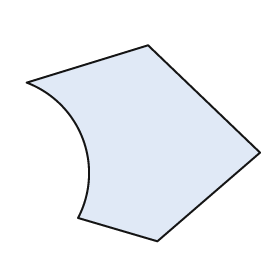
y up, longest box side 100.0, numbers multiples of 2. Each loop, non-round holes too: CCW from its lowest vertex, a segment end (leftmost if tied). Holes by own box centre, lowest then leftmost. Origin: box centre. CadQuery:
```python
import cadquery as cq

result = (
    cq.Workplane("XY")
    .moveTo(6.0, -42.0)
    .lineTo(50.0, -4.0)
    .lineTo(2.0, 42.0)
    .lineTo(-50.0, 26.0)
    .threePointArc((-26.0, 2.0), (-28.0, -32.0))
    .close()
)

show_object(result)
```